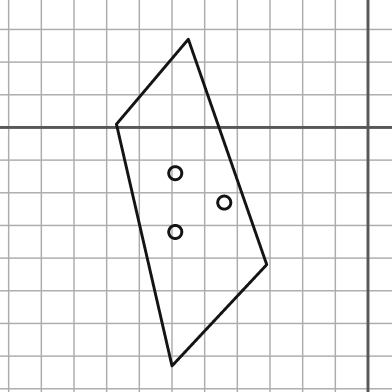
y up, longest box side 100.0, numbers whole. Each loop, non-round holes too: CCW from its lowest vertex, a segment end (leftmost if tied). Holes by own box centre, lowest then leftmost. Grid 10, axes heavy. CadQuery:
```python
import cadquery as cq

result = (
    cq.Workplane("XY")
    .moveTo(-60.0, -73.0)
    .lineTo(-31.0, -42.0)
    .lineTo(-55.0, 27.0)
    .lineTo(-77.0, 1.0)
    .close()
    .moveTo(-59.0, -32.0)
    .circle(2.0)
    .moveTo(-44.0, -23.0)
    .circle(2.0)
    .moveTo(-59.0, -14.0)
    .circle(2.0)
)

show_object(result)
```